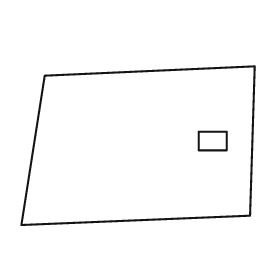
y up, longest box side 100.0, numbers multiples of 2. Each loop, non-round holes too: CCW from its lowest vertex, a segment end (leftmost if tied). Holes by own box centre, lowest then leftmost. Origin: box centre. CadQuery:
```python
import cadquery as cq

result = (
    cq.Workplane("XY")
    .moveTo(-50.0, -34.0)
    .lineTo(48.0, -30.0)
    .lineTo(50.0, 34.0)
    .lineTo(-40.0, 30.0)
    .close()
    .moveTo(26.0, -2.0)
    .lineTo(38.0, -2.0)
    .lineTo(38.0, 6.0)
    .lineTo(26.0, 6.0)
    .close()
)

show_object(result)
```